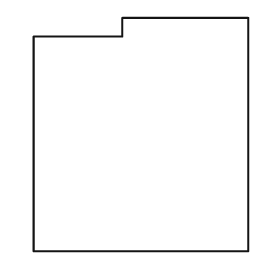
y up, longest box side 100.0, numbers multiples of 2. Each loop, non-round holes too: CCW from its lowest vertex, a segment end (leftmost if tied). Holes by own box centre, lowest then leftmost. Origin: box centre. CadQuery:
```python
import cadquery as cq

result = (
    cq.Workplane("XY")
    .moveTo(-46.0, -50.0)
    .lineTo(46.0, -50.0)
    .lineTo(46.0, 50.0)
    .lineTo(-8.0, 50.0)
    .lineTo(-8.0, 42.0)
    .lineTo(-46.0, 42.0)
    .close()
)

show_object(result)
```